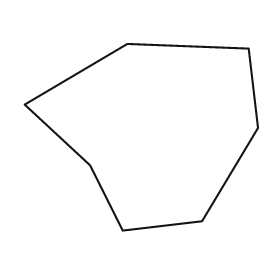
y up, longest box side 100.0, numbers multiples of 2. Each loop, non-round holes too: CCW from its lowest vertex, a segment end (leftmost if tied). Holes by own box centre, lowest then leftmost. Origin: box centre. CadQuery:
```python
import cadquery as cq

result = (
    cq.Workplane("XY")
    .moveTo(-8.0, -40.0)
    .lineTo(26.0, -36.0)
    .lineTo(50.0, 4.0)
    .lineTo(46.0, 38.0)
    .lineTo(-6.0, 40.0)
    .lineTo(-50.0, 14.0)
    .lineTo(-22.0, -12.0)
    .close()
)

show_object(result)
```